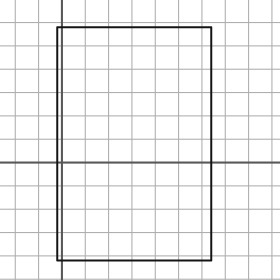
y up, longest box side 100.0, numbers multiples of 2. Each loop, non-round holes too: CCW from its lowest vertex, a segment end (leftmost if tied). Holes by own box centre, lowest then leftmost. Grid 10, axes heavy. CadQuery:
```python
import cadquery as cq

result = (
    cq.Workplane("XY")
    .moveTo(-2.0, -42.0)
    .lineTo(64.0, -42.0)
    .lineTo(64.0, 58.0)
    .lineTo(-2.0, 58.0)
    .close()
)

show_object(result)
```